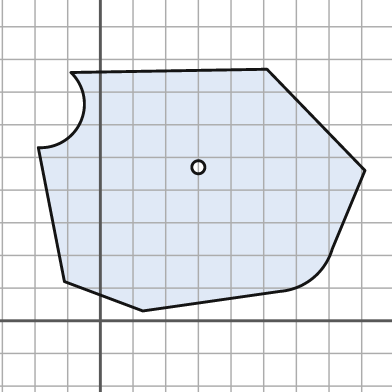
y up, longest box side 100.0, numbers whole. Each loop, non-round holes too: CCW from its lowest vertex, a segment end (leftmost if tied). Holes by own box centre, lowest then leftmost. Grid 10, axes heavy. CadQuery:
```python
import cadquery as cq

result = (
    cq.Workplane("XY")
    .moveTo(13.0, 3.0)
    .lineTo(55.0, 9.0)
    .threePointArc((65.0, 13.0), (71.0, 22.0))
    .lineTo(81.0, 46.0)
    .lineTo(51.0, 77.0)
    .lineTo(-9.0, 76.0)
    .threePointArc((-6.0, 61.0), (-19.0, 53.0))
    .lineTo(-11.0, 12.0)
    .close()
    .moveTo(30.0, 47.0)
    .circle(2.0)
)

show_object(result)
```